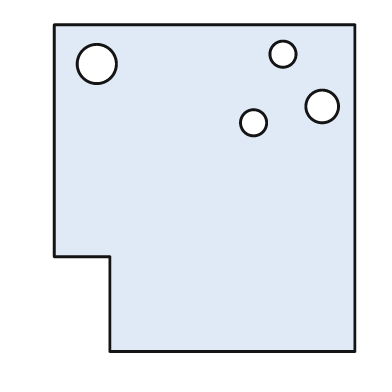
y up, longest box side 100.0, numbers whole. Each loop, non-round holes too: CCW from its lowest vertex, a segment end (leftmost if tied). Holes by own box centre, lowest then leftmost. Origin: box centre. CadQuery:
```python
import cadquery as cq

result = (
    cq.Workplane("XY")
    .moveTo(-29.0, -50.0)
    .lineTo(46.0, -50.0)
    .lineTo(46.0, 50.0)
    .lineTo(-46.0, 50.0)
    .lineTo(-46.0, -21.0)
    .lineTo(-29.0, -21.0)
    .close()
    .moveTo(15.0, 20.0)
    .circle(4.0)
    .moveTo(36.0, 25.0)
    .circle(5.0)
    .moveTo(-33.0, 38.0)
    .circle(6.0)
    .moveTo(24.0, 41.0)
    .circle(4.0)
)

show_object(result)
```